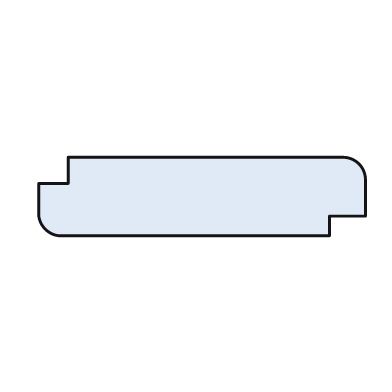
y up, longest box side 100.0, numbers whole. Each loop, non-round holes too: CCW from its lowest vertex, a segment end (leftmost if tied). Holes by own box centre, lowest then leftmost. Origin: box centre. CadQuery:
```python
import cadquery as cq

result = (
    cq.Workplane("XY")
    .moveTo(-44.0, -12.0)
    .lineTo(39.0, -12.0)
    .lineTo(39.0, -6.0)
    .lineTo(50.0, -6.0)
    .lineTo(50.0, 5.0)
    .threePointArc((48.0, 10.0), (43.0, 12.0))
    .lineTo(-41.0, 12.0)
    .lineTo(-41.0, 4.0)
    .lineTo(-50.0, 4.0)
    .lineTo(-50.0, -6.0)
    .threePointArc((-48.0, -10.0), (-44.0, -12.0))
    .close()
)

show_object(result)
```